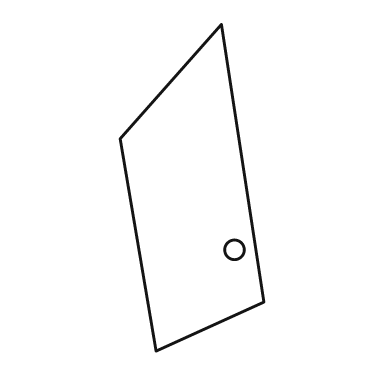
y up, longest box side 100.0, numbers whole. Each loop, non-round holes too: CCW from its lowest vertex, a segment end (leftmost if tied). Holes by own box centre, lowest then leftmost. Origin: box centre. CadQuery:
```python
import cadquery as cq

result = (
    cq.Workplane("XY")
    .moveTo(-11.0, -50.0)
    .lineTo(22.0, -35.0)
    .lineTo(9.0, 50.0)
    .lineTo(-22.0, 15.0)
    .close()
    .moveTo(13.0, -19.0)
    .circle(3.0)
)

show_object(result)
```